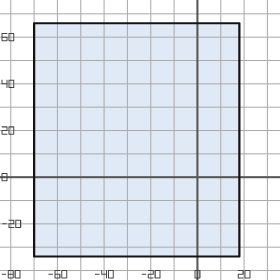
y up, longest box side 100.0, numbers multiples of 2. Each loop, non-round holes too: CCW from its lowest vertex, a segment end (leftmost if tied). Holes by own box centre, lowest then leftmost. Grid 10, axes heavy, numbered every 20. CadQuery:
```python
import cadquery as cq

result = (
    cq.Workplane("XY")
    .moveTo(-70.0, -34.0)
    .lineTo(18.0, -34.0)
    .lineTo(18.0, 66.0)
    .lineTo(-70.0, 66.0)
    .close()
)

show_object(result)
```